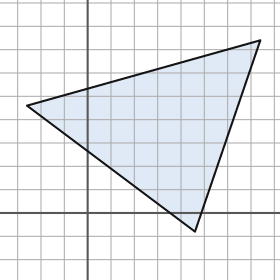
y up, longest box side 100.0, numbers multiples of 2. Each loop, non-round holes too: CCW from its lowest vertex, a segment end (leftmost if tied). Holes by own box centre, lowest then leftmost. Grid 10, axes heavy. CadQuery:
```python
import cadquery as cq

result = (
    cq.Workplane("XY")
    .moveTo(46.0, -8.0)
    .lineTo(74.0, 74.0)
    .lineTo(-26.0, 46.0)
    .close()
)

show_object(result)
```